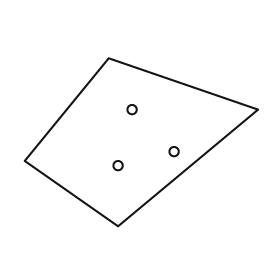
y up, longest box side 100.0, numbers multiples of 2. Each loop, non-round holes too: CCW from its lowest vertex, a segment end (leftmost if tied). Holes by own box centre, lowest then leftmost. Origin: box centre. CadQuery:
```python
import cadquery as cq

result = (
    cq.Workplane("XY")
    .moveTo(-10.0, -36.0)
    .lineTo(50.0, 14.0)
    .lineTo(-14.0, 36.0)
    .lineTo(-50.0, -8.0)
    .close()
    .moveTo(-10.0, -10.0)
    .circle(2.0)
    .moveTo(14.0, -4.0)
    .circle(2.0)
    .moveTo(-4.0, 14.0)
    .circle(2.0)
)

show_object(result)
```